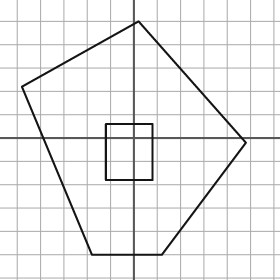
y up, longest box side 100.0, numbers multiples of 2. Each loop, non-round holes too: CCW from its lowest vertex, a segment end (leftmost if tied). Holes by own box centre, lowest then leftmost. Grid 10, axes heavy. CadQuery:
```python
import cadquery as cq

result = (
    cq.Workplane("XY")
    .moveTo(-18.0, -50.0)
    .lineTo(12.0, -50.0)
    .lineTo(48.0, -2.0)
    .lineTo(2.0, 50.0)
    .lineTo(-48.0, 22.0)
    .close()
    .moveTo(-12.0, -18.0)
    .lineTo(8.0, -18.0)
    .lineTo(8.0, 6.0)
    .lineTo(-12.0, 6.0)
    .close()
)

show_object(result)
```